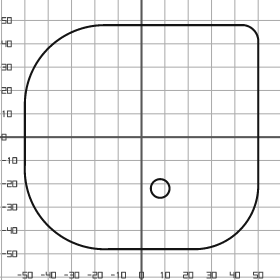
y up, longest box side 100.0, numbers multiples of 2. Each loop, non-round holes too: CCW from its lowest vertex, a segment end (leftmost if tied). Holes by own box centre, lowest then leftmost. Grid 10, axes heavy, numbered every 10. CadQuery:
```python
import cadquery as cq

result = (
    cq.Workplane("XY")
    .moveTo(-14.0, -48.0)
    .lineTo(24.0, -48.0)
    .threePointArc((42.0, -40.0), (50.0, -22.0))
    .lineTo(50.0, 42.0)
    .threePointArc((48.0, 46.0), (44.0, 48.0))
    .lineTo(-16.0, 48.0)
    .threePointArc((-40.0, 38.0), (-50.0, 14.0))
    .lineTo(-50.0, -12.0)
    .threePointArc((-40.0, -38.0), (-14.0, -48.0))
    .close()
    .moveTo(8.0, -22.0)
    .circle(4.0)
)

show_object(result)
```